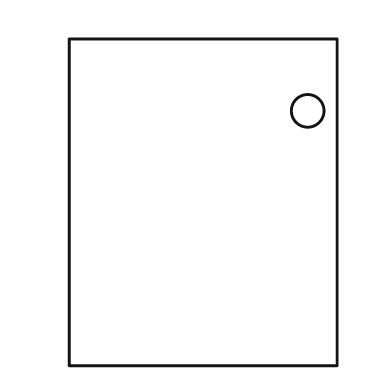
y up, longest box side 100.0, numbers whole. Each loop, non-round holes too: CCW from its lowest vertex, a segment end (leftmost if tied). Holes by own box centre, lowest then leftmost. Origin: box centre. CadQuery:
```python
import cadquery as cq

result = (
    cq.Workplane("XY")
    .moveTo(-41.0, -50.0)
    .lineTo(41.0, -50.0)
    .lineTo(41.0, 50.0)
    .lineTo(-41.0, 50.0)
    .close()
    .moveTo(32.0, 28.0)
    .circle(5.0)
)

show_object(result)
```